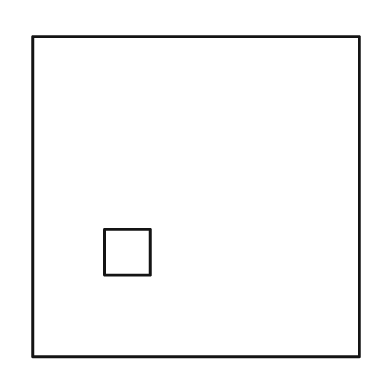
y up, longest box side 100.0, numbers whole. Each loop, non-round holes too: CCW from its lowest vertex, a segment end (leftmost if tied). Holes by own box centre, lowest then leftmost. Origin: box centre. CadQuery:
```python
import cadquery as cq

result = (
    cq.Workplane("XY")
    .moveTo(-50.0, -49.0)
    .lineTo(50.0, -49.0)
    .lineTo(50.0, 49.0)
    .lineTo(-50.0, 49.0)
    .close()
    .moveTo(-28.0, -24.0)
    .lineTo(-14.0, -24.0)
    .lineTo(-14.0, -10.0)
    .lineTo(-28.0, -10.0)
    .close()
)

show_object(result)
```